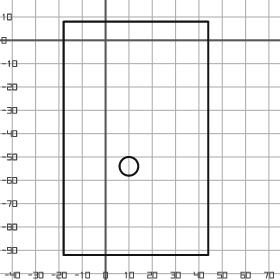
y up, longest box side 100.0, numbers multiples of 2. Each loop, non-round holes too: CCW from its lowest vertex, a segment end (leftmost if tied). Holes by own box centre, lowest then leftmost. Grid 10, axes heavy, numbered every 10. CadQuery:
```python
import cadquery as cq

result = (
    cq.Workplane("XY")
    .moveTo(-18.0, -92.0)
    .lineTo(44.0, -92.0)
    .lineTo(44.0, 8.0)
    .lineTo(-18.0, 8.0)
    .close()
    .moveTo(10.0, -54.0)
    .circle(4.0)
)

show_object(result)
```